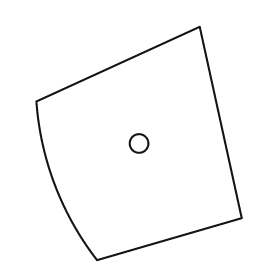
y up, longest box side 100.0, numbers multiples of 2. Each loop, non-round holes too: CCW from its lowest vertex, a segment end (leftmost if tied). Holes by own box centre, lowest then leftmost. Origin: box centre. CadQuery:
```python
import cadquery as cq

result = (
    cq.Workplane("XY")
    .moveTo(-18.0, -50.0)
    .lineTo(44.0, -32.0)
    .lineTo(26.0, 50.0)
    .lineTo(-44.0, 18.0)
    .threePointArc((-36.0, -18.0), (-18.0, -50.0))
    .close()
    .moveTo(0.0, 0.0)
    .circle(4.0)
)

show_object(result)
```